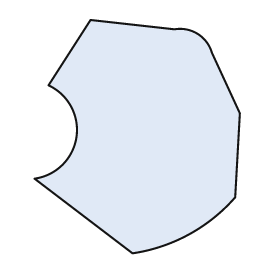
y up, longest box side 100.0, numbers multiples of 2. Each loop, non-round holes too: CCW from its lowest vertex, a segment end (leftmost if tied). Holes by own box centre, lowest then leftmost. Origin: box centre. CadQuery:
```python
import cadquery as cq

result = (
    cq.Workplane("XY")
    .moveTo(-2.0, -50.0)
    .threePointArc((22.0, -42.0), (42.0, -26.0))
    .lineTo(44.0, 10.0)
    .lineTo(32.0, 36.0)
    .threePointArc((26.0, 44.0), (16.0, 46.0))
    .lineTo(-20.0, 50.0)
    .lineTo(-38.0, 22.0)
    .threePointArc((-26.0, 0.0), (-44.0, -18.0))
    .close()
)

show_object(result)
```